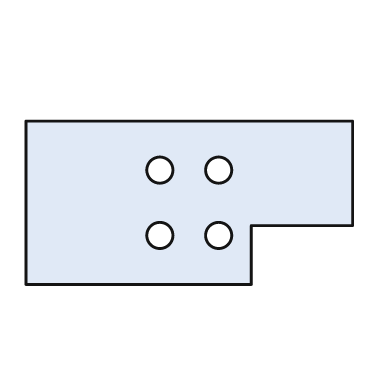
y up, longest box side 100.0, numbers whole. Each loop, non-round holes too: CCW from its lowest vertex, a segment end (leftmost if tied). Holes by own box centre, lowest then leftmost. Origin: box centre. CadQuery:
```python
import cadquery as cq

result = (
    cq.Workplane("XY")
    .moveTo(-50.0, -25.0)
    .lineTo(19.0, -25.0)
    .lineTo(19.0, -7.0)
    .lineTo(50.0, -7.0)
    .lineTo(50.0, 25.0)
    .lineTo(-50.0, 25.0)
    .close()
    .moveTo(-9.0, -10.0)
    .circle(4.0)
    .moveTo(9.0, -10.0)
    .circle(4.0)
    .moveTo(-9.0, 10.0)
    .circle(4.0)
    .moveTo(9.0, 10.0)
    .circle(4.0)
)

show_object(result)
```